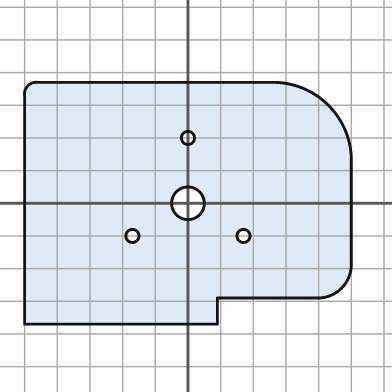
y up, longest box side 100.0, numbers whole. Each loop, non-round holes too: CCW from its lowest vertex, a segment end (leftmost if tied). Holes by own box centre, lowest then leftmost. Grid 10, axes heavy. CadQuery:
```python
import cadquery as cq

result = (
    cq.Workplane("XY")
    .moveTo(-50.0, -37.0)
    .lineTo(9.0, -37.0)
    .lineTo(9.0, -29.0)
    .lineTo(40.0, -29.0)
    .threePointArc((47.0, -26.0), (50.0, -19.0))
    .lineTo(50.0, 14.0)
    .threePointArc((43.0, 30.0), (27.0, 37.0))
    .lineTo(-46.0, 37.0)
    .threePointArc((-49.0, 36.0), (-50.0, 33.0))
    .close()
    .moveTo(-17.0, -10.0)
    .circle(2.0)
    .moveTo(17.0, -10.0)
    .circle(2.0)
    .moveTo(0.0, 0.0)
    .circle(5.0)
    .moveTo(0.0, 20.0)
    .circle(2.0)
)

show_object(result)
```